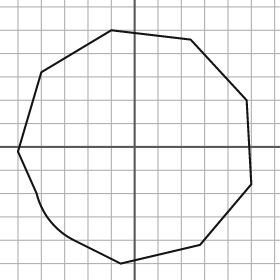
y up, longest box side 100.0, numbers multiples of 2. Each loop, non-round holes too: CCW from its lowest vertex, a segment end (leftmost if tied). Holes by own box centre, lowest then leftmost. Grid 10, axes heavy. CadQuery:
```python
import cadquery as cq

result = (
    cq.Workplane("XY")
    .moveTo(-6.0, -50.0)
    .lineTo(28.0, -42.0)
    .lineTo(50.0, -16.0)
    .lineTo(48.0, 20.0)
    .lineTo(24.0, 46.0)
    .lineTo(-10.0, 50.0)
    .lineTo(-40.0, 32.0)
    .lineTo(-50.0, -2.0)
    .lineTo(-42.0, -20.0)
    .threePointArc((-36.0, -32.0), (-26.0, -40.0))
    .close()
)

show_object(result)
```